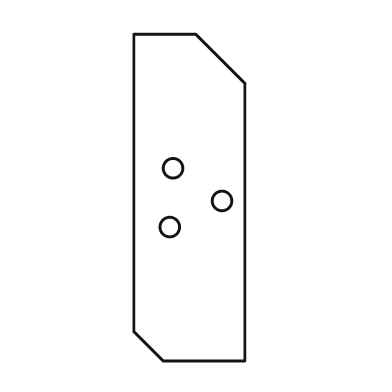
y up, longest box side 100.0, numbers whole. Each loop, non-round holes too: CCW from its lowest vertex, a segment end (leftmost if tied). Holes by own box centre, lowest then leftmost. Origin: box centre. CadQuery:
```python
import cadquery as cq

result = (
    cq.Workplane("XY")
    .moveTo(-8.0, -50.0)
    .lineTo(17.0, -50.0)
    .lineTo(17.0, 35.0)
    .lineTo(2.0, 50.0)
    .lineTo(-17.0, 50.0)
    .lineTo(-17.0, -41.0)
    .close()
    .moveTo(-6.0, -9.0)
    .circle(3.0)
    .moveTo(10.0, -1.0)
    .circle(3.0)
    .moveTo(-5.0, 9.0)
    .circle(3.0)
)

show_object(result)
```